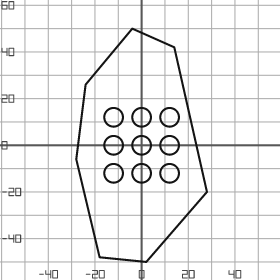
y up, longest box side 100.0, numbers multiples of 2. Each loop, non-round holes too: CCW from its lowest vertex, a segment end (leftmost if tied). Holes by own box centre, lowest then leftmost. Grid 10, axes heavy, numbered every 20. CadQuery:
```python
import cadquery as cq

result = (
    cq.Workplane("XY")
    .moveTo(2.0, -50.0)
    .lineTo(28.0, -20.0)
    .lineTo(14.0, 42.0)
    .lineTo(-4.0, 50.0)
    .lineTo(-24.0, 26.0)
    .lineTo(-28.0, -6.0)
    .lineTo(-18.0, -48.0)
    .close()
    .moveTo(-12.0, -12.0)
    .circle(4.0)
    .moveTo(0.0, -12.0)
    .circle(4.0)
    .moveTo(12.0, -12.0)
    .circle(4.0)
    .moveTo(-12.0, 0.0)
    .circle(4.0)
    .moveTo(0.0, 0.0)
    .circle(4.0)
    .moveTo(12.0, 0.0)
    .circle(4.0)
    .moveTo(-12.0, 12.0)
    .circle(4.0)
    .moveTo(0.0, 12.0)
    .circle(4.0)
    .moveTo(12.0, 12.0)
    .circle(4.0)
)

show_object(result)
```